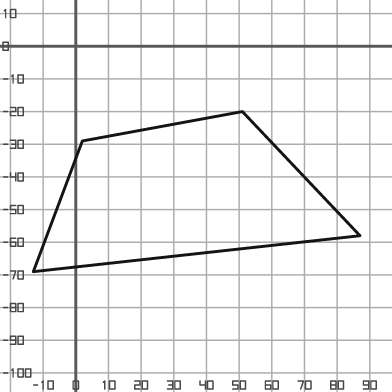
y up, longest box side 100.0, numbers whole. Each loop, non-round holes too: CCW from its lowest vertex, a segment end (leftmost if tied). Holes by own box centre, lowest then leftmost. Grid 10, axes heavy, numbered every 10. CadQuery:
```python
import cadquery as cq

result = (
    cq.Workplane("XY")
    .moveTo(-13.0, -69.0)
    .lineTo(87.0, -58.0)
    .lineTo(51.0, -20.0)
    .lineTo(2.0, -29.0)
    .close()
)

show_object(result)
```